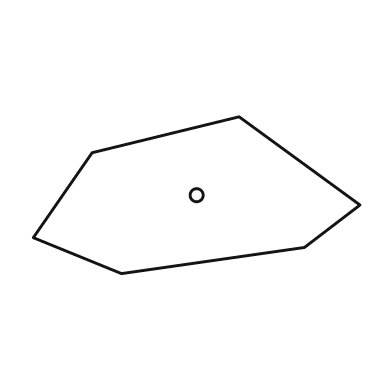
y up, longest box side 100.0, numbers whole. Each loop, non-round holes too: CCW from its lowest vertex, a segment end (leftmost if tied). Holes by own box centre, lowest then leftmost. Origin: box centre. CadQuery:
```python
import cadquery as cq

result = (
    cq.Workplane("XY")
    .moveTo(-23.0, -24.0)
    .lineTo(33.0, -16.0)
    .lineTo(50.0, -3.0)
    .lineTo(13.0, 24.0)
    .lineTo(-32.0, 13.0)
    .lineTo(-50.0, -13.0)
    .close()
    .moveTo(0.0, 0.0)
    .circle(2.0)
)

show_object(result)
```